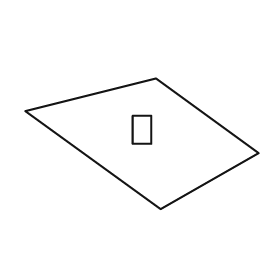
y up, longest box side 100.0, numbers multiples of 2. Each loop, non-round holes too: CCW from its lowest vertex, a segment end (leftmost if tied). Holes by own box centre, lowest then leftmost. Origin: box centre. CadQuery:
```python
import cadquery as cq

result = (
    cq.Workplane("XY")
    .moveTo(8.0, -28.0)
    .lineTo(50.0, -4.0)
    .lineTo(6.0, 28.0)
    .lineTo(-50.0, 14.0)
    .close()
    .moveTo(-4.0, 0.0)
    .lineTo(4.0, 0.0)
    .lineTo(4.0, 12.0)
    .lineTo(-4.0, 12.0)
    .close()
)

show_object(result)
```